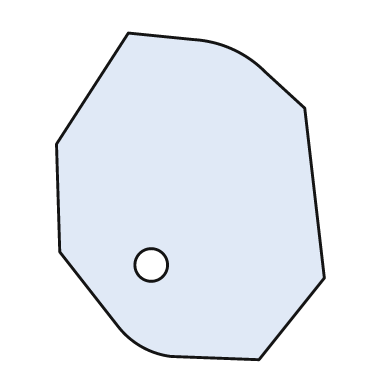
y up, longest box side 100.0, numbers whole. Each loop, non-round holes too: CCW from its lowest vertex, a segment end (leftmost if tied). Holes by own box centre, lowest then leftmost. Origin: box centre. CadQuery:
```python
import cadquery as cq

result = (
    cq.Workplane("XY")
    .moveTo(21.0, -50.0)
    .lineTo(41.0, -25.0)
    .lineTo(35.0, 27.0)
    .lineTo(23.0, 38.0)
    .threePointArc((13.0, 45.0), (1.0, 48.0))
    .lineTo(-19.0, 50.0)
    .lineTo(-41.0, 16.0)
    .lineTo(-40.0, -17.0)
    .lineTo(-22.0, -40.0)
    .threePointArc((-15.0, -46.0), (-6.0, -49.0))
    .close()
    .moveTo(-12.0, -21.0)
    .circle(5.0)
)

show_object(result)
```